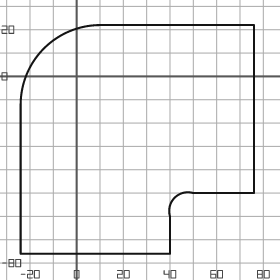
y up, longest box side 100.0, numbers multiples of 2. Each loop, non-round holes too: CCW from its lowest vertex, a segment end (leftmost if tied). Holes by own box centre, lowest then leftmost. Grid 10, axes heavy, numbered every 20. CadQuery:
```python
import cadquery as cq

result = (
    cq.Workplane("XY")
    .moveTo(-24.0, -76.0)
    .lineTo(40.0, -76.0)
    .lineTo(40.0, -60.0)
    .threePointArc((42.0, -52.0), (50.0, -50.0))
    .lineTo(76.0, -50.0)
    .lineTo(76.0, 22.0)
    .lineTo(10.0, 22.0)
    .threePointArc((-14.0, 12.0), (-24.0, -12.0))
    .close()
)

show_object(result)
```